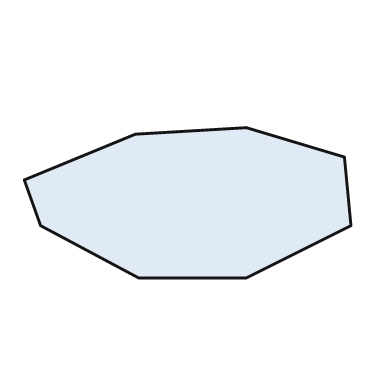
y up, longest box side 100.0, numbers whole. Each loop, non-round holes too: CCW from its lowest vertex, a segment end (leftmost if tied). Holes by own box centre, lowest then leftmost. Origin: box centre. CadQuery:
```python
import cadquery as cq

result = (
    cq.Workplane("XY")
    .moveTo(-15.0, -23.0)
    .lineTo(18.0, -23.0)
    .lineTo(50.0, -7.0)
    .lineTo(48.0, 14.0)
    .lineTo(18.0, 23.0)
    .lineTo(-16.0, 21.0)
    .lineTo(-50.0, 7.0)
    .lineTo(-45.0, -7.0)
    .close()
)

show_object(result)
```